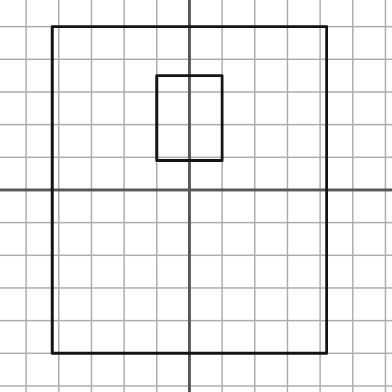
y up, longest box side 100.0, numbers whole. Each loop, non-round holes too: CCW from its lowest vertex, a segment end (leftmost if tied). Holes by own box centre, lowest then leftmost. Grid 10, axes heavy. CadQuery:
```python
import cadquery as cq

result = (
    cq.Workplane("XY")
    .moveTo(-42.0, -50.0)
    .lineTo(42.0, -50.0)
    .lineTo(42.0, 50.0)
    .lineTo(-42.0, 50.0)
    .close()
    .moveTo(-10.0, 9.0)
    .lineTo(10.0, 9.0)
    .lineTo(10.0, 35.0)
    .lineTo(-10.0, 35.0)
    .close()
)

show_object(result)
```